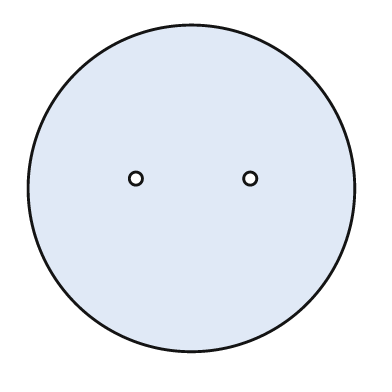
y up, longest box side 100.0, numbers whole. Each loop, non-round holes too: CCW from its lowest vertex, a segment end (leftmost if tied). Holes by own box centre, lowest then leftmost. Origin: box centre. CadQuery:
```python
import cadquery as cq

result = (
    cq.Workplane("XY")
    .moveTo(0.0, 0.0)
    .circle(50.0)
    .moveTo(-17.0, 3.0)
    .circle(2.0)
    .moveTo(18.0, 3.0)
    .circle(2.0)
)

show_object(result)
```